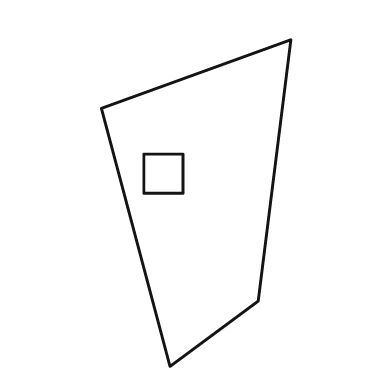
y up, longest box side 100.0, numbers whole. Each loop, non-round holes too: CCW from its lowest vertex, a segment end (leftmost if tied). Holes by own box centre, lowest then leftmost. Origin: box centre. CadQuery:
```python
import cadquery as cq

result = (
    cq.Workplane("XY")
    .moveTo(-8.0, -50.0)
    .lineTo(19.0, -30.0)
    .lineTo(29.0, 50.0)
    .lineTo(-29.0, 29.0)
    .close()
    .moveTo(-16.0, 3.0)
    .lineTo(-4.0, 3.0)
    .lineTo(-4.0, 15.0)
    .lineTo(-16.0, 15.0)
    .close()
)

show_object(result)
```